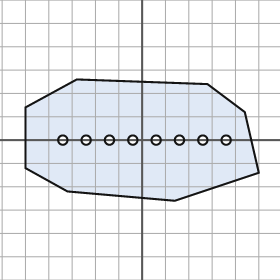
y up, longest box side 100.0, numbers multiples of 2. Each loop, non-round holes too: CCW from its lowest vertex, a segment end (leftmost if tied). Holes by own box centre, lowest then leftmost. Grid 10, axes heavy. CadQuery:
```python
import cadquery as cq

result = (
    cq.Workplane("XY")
    .moveTo(14.0, -26.0)
    .lineTo(50.0, -14.0)
    .lineTo(44.0, 12.0)
    .lineTo(28.0, 24.0)
    .lineTo(-28.0, 26.0)
    .lineTo(-50.0, 14.0)
    .lineTo(-50.0, -12.0)
    .lineTo(-32.0, -22.0)
    .close()
    .moveTo(-34.0, 0.0)
    .circle(2.0)
    .moveTo(-24.0, 0.0)
    .circle(2.0)
    .moveTo(-14.0, 0.0)
    .circle(2.0)
    .moveTo(-4.0, 0.0)
    .circle(2.0)
    .moveTo(6.0, 0.0)
    .circle(2.0)
    .moveTo(16.0, 0.0)
    .circle(2.0)
    .moveTo(26.0, 0.0)
    .circle(2.0)
    .moveTo(36.0, 0.0)
    .circle(2.0)
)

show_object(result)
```